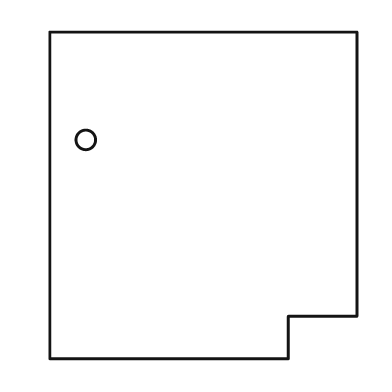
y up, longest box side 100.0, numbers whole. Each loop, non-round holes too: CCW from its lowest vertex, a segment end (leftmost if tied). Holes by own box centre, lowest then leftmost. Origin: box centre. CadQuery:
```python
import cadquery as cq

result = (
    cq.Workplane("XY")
    .moveTo(-47.0, -50.0)
    .lineTo(26.0, -50.0)
    .lineTo(26.0, -37.0)
    .lineTo(47.0, -37.0)
    .lineTo(47.0, 50.0)
    .lineTo(-47.0, 50.0)
    .close()
    .moveTo(-36.0, 17.0)
    .circle(3.0)
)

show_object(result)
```